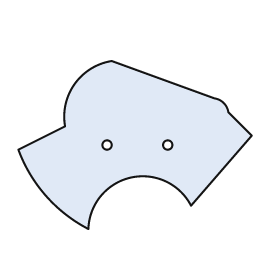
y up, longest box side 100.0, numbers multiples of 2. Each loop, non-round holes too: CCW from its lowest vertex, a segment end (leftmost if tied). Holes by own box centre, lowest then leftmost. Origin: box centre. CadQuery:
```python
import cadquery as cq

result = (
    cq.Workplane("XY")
    .moveTo(-20.0, -36.0)
    .threePointArc((-2.0, -14.0), (24.0, -26.0))
    .lineTo(50.0, 4.0)
    .lineTo(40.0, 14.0)
    .threePointArc((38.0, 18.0), (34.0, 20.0))
    .lineTo(-10.0, 36.0)
    .threePointArc((-26.0, 26.0), (-30.0, 8.0))
    .lineTo(-50.0, -2.0)
    .threePointArc((-38.0, -22.0), (-20.0, -36.0))
    .close()
    .moveTo(-12.0, 0.0)
    .circle(2.0)
    .moveTo(14.0, 0.0)
    .circle(2.0)
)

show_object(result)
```